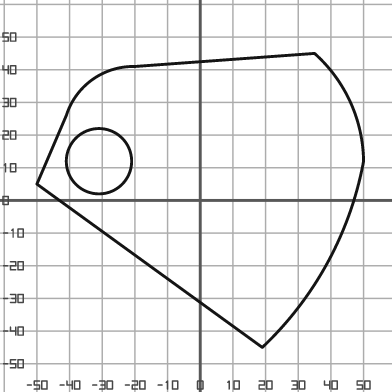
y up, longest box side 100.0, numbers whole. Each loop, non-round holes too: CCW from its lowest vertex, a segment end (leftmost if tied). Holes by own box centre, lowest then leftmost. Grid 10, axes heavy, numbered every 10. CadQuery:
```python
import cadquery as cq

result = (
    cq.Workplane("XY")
    .moveTo(19.0, -45.0)
    .threePointArc((39.0, -19.0), (50.0, 12.0))
    .threePointArc((46.0, 30.0), (35.0, 45.0))
    .lineTo(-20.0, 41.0)
    .threePointArc((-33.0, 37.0), (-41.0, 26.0))
    .lineTo(-50.0, 5.0)
    .close()
    .moveTo(-31.0, 12.0)
    .circle(10.0)
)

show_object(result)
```